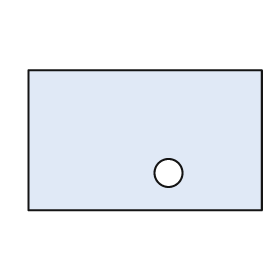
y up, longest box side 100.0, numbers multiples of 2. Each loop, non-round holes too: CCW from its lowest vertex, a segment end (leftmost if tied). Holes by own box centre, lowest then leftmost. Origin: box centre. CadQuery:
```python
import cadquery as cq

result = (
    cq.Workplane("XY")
    .moveTo(-50.0, -30.0)
    .lineTo(50.0, -30.0)
    .lineTo(50.0, 30.0)
    .lineTo(-50.0, 30.0)
    .close()
    .moveTo(10.0, -14.0)
    .circle(6.0)
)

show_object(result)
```